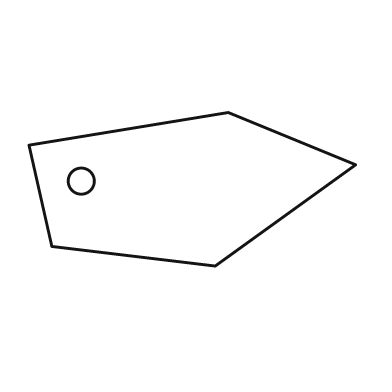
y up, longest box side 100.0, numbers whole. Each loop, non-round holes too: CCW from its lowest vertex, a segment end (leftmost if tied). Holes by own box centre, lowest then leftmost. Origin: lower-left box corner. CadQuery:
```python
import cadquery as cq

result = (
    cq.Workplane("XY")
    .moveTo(57.0, 0.0)
    .lineTo(100.0, 31.0)
    .lineTo(61.0, 47.0)
    .lineTo(0.0, 37.0)
    .lineTo(7.0, 6.0)
    .close()
    .moveTo(16.0, 26.0)
    .circle(4.0)
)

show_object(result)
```